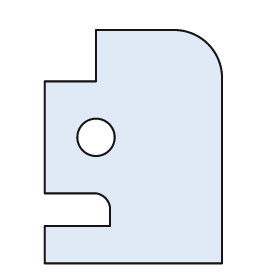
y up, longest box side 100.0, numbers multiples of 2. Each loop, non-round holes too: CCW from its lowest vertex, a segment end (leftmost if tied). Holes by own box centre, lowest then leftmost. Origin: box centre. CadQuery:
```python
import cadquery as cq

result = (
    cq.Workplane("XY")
    .moveTo(-38.0, -50.0)
    .lineTo(38.0, -50.0)
    .lineTo(38.0, 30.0)
    .threePointArc((32.0, 44.0), (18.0, 50.0))
    .lineTo(-16.0, 50.0)
    .lineTo(-16.0, 28.0)
    .lineTo(-38.0, 28.0)
    .lineTo(-38.0, -20.0)
    .lineTo(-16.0, -20.0)
    .threePointArc((-12.0, -22.0), (-10.0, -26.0))
    .lineTo(-10.0, -34.0)
    .lineTo(-38.0, -34.0)
    .close()
    .moveTo(-16.0, 4.0)
    .circle(8.0)
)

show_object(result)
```